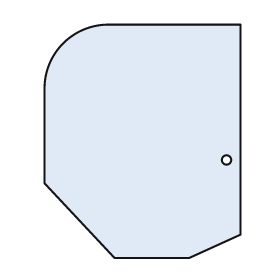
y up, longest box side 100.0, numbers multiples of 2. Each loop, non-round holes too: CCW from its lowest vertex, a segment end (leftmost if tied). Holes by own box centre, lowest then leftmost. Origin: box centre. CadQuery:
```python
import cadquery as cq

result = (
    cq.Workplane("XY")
    .moveTo(-12.0, -50.0)
    .lineTo(20.0, -50.0)
    .lineTo(42.0, -40.0)
    .lineTo(42.0, 50.0)
    .lineTo(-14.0, 50.0)
    .threePointArc((-34.0, 42.0), (-42.0, 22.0))
    .lineTo(-42.0, -18.0)
    .close()
    .moveTo(36.0, -8.0)
    .circle(2.0)
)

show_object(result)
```